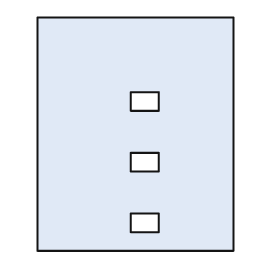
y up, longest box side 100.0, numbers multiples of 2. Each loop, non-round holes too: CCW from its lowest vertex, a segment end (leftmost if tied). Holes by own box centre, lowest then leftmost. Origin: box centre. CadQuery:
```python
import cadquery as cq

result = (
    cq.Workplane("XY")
    .moveTo(-42.0, -50.0)
    .lineTo(42.0, -50.0)
    .lineTo(42.0, 50.0)
    .lineTo(-42.0, 50.0)
    .close()
    .moveTo(-2.0, -42.0)
    .lineTo(10.0, -42.0)
    .lineTo(10.0, -34.0)
    .lineTo(-2.0, -34.0)
    .close()
    .moveTo(-2.0, -16.0)
    .lineTo(10.0, -16.0)
    .lineTo(10.0, -8.0)
    .lineTo(-2.0, -8.0)
    .close()
    .moveTo(-2.0, 10.0)
    .lineTo(10.0, 10.0)
    .lineTo(10.0, 18.0)
    .lineTo(-2.0, 18.0)
    .close()
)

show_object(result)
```